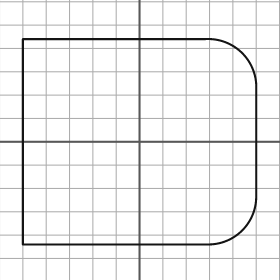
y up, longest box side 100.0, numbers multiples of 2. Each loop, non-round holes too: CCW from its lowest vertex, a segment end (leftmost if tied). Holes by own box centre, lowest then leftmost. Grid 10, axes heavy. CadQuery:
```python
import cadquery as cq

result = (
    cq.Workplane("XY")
    .moveTo(-50.0, -44.0)
    .lineTo(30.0, -44.0)
    .threePointArc((44.0, -38.0), (50.0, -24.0))
    .lineTo(50.0, 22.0)
    .threePointArc((44.0, 38.0), (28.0, 44.0))
    .lineTo(-50.0, 44.0)
    .close()
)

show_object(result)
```